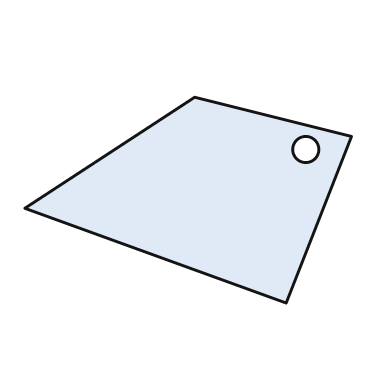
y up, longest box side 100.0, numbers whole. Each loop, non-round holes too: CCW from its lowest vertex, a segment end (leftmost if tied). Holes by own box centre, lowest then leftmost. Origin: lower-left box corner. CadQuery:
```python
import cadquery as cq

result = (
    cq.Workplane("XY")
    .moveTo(80.0, 0.0)
    .lineTo(100.0, 51.0)
    .lineTo(52.0, 63.0)
    .lineTo(0.0, 29.0)
    .close()
    .moveTo(86.0, 47.0)
    .circle(4.0)
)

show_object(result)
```